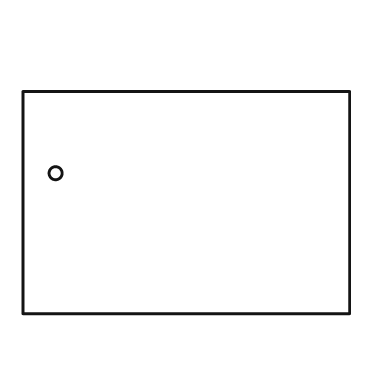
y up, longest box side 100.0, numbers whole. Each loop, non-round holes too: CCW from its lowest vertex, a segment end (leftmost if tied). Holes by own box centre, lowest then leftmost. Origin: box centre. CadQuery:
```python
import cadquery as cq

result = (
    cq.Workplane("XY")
    .moveTo(-50.0, -34.0)
    .lineTo(50.0, -34.0)
    .lineTo(50.0, 34.0)
    .lineTo(-50.0, 34.0)
    .close()
    .moveTo(-40.0, 9.0)
    .circle(2.0)
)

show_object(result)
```